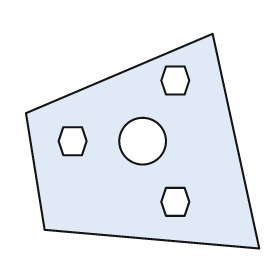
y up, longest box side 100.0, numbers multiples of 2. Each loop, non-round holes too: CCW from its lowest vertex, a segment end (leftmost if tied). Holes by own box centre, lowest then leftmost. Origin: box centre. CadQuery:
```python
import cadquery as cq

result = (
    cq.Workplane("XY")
    .moveTo(50.0, -46.0)
    .lineTo(30.0, 46.0)
    .lineTo(-50.0, 12.0)
    .lineTo(-42.0, -38.0)
    .close()
    .moveTo(10.0, -32.0)
    .lineTo(18.0, -32.0)
    .lineTo(20.0, -26.0)
    .lineTo(18.0, -20.0)
    .lineTo(10.0, -20.0)
    .lineTo(8.0, -26.0)
    .close()
    .moveTo(-34.0, -6.0)
    .lineTo(-26.0, -6.0)
    .lineTo(-24.0, 0.0)
    .lineTo(-26.0, 6.0)
    .lineTo(-34.0, 6.0)
    .lineTo(-36.0, 0.0)
    .close()
    .moveTo(0.0, 0.0)
    .circle(10.0)
    .moveTo(10.0, 20.0)
    .lineTo(18.0, 20.0)
    .lineTo(20.0, 26.0)
    .lineTo(18.0, 32.0)
    .lineTo(10.0, 32.0)
    .lineTo(8.0, 26.0)
    .close()
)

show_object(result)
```